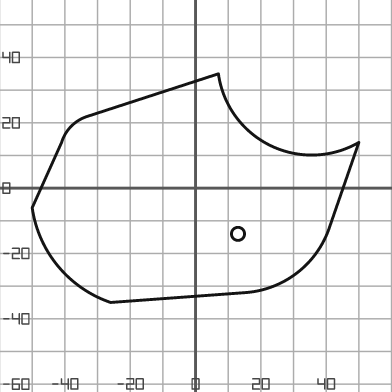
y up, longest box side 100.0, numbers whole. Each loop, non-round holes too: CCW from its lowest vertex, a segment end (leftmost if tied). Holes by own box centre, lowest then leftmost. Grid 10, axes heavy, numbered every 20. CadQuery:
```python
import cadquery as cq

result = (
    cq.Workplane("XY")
    .moveTo(-26.0, -35.0)
    .lineTo(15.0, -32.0)
    .threePointArc((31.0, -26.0), (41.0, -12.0))
    .lineTo(50.0, 14.0)
    .threePointArc((23.0, 13.0), (7.0, 35.0))
    .lineTo(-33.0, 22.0)
    .threePointArc((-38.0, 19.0), (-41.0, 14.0))
    .lineTo(-50.0, -6.0)
    .threePointArc((-42.0, -24.0), (-26.0, -35.0))
    .close()
    .moveTo(13.0, -14.0)
    .circle(2.0)
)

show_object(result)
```